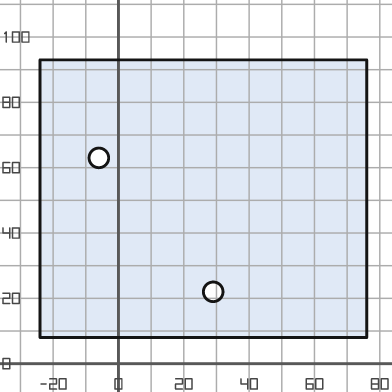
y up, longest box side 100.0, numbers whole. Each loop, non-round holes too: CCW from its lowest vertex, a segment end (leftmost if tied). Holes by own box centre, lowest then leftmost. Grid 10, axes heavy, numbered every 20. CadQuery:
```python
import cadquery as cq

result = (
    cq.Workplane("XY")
    .moveTo(-24.0, 8.0)
    .lineTo(76.0, 8.0)
    .lineTo(76.0, 93.0)
    .lineTo(-24.0, 93.0)
    .close()
    .moveTo(29.0, 22.0)
    .circle(3.0)
    .moveTo(-6.0, 63.0)
    .circle(3.0)
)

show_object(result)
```